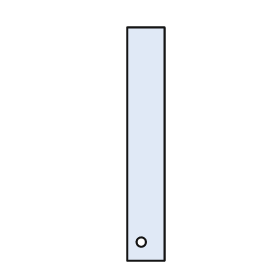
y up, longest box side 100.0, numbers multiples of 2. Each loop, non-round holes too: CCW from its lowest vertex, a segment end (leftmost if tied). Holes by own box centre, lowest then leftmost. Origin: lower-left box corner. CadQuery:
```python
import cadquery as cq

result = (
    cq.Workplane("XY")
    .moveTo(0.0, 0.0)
    .lineTo(16.0, 0.0)
    .lineTo(16.0, 100.0)
    .lineTo(0.0, 100.0)
    .close()
    .moveTo(6.0, 8.0)
    .circle(2.0)
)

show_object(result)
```